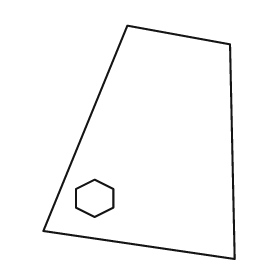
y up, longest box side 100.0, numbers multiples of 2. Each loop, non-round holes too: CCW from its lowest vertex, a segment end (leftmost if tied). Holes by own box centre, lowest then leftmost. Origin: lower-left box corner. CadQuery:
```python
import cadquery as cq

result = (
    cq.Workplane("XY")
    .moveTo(82.0, 0.0)
    .lineTo(80.0, 92.0)
    .lineTo(36.0, 100.0)
    .lineTo(0.0, 12.0)
    .close()
    .moveTo(22.0, 18.0)
    .lineTo(30.0, 22.0)
    .lineTo(30.0, 30.0)
    .lineTo(22.0, 34.0)
    .lineTo(14.0, 30.0)
    .lineTo(14.0, 22.0)
    .close()
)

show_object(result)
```